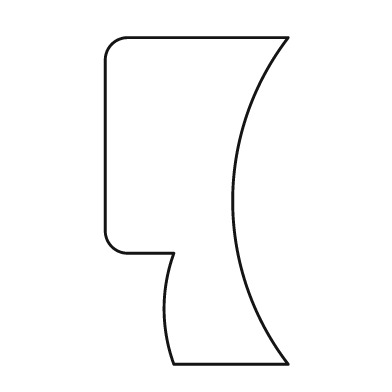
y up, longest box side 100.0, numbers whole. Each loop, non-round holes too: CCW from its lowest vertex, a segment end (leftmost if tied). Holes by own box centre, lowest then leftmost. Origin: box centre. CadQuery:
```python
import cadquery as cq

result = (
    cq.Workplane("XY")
    .moveTo(-7.0, -50.0)
    .lineTo(28.0, -50.0)
    .threePointArc((11.0, 0.0), (28.0, 50.0))
    .lineTo(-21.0, 50.0)
    .threePointArc((-26.0, 48.0), (-28.0, 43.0))
    .lineTo(-28.0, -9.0)
    .threePointArc((-26.0, -14.0), (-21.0, -16.0))
    .lineTo(-7.0, -16.0)
    .threePointArc((-10.0, -33.0), (-7.0, -50.0))
    .close()
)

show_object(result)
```